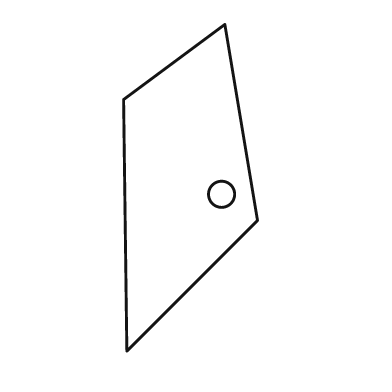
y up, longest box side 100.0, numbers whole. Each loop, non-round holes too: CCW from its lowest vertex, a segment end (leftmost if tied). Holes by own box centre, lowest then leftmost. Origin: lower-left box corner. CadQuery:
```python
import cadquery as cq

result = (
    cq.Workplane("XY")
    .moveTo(1.0, 0.0)
    .lineTo(41.0, 40.0)
    .lineTo(31.0, 100.0)
    .lineTo(0.0, 77.0)
    .close()
    .moveTo(30.0, 48.0)
    .circle(4.0)
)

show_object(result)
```